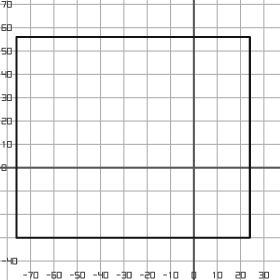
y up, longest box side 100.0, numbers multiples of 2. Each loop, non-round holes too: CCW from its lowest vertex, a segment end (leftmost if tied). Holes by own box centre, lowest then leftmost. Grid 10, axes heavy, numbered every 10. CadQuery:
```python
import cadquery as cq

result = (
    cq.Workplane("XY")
    .moveTo(-76.0, -30.0)
    .lineTo(24.0, -30.0)
    .lineTo(24.0, 56.0)
    .lineTo(-76.0, 56.0)
    .close()
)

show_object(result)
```